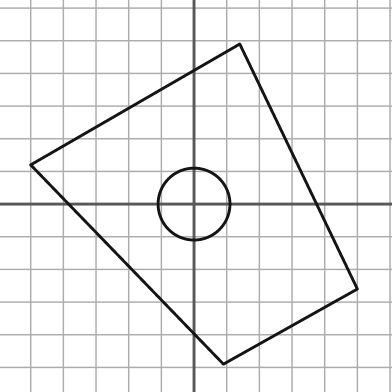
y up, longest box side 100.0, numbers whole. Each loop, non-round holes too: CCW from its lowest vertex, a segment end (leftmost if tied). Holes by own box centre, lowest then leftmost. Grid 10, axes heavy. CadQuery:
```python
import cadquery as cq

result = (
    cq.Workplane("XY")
    .moveTo(9.0, -49.0)
    .lineTo(50.0, -26.0)
    .lineTo(14.0, 49.0)
    .lineTo(-50.0, 12.0)
    .close()
    .moveTo(0.0, 0.0)
    .circle(11.0)
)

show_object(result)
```